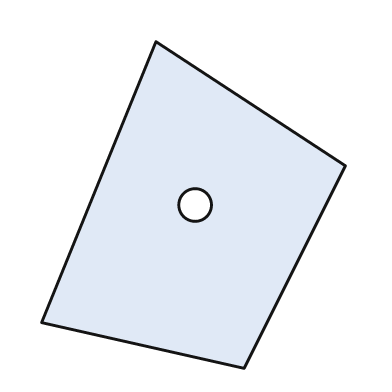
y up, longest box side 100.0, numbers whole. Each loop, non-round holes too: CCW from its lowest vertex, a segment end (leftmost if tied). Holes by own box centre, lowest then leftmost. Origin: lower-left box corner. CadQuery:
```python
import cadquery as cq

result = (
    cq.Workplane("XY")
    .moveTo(62.0, 0.0)
    .lineTo(93.0, 62.0)
    .lineTo(35.0, 100.0)
    .lineTo(0.0, 14.0)
    .close()
    .moveTo(47.0, 50.0)
    .circle(5.0)
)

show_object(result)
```